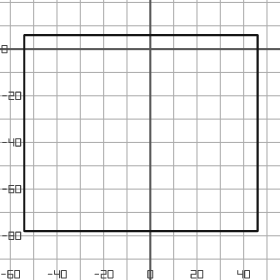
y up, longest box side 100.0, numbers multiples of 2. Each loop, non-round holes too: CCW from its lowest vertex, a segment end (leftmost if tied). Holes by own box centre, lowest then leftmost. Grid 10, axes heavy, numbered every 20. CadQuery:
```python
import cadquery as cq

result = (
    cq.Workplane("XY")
    .moveTo(-54.0, -78.0)
    .lineTo(46.0, -78.0)
    .lineTo(46.0, 6.0)
    .lineTo(-54.0, 6.0)
    .close()
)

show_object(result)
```